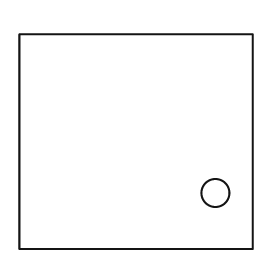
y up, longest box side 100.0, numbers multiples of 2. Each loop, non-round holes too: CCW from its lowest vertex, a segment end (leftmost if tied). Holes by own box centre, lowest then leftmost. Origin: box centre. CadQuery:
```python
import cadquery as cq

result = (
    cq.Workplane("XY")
    .moveTo(-50.0, -46.0)
    .lineTo(50.0, -46.0)
    .lineTo(50.0, 46.0)
    .lineTo(-50.0, 46.0)
    .close()
    .moveTo(34.0, -22.0)
    .circle(6.0)
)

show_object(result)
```